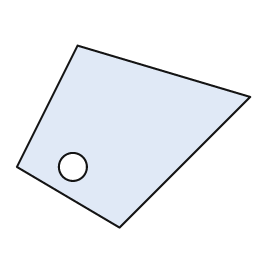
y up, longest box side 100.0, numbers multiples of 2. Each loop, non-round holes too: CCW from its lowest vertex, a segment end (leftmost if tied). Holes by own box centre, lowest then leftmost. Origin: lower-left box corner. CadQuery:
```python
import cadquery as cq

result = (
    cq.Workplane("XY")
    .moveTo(44.0, 0.0)
    .lineTo(100.0, 56.0)
    .lineTo(26.0, 78.0)
    .lineTo(0.0, 26.0)
    .close()
    .moveTo(24.0, 26.0)
    .circle(6.0)
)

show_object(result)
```